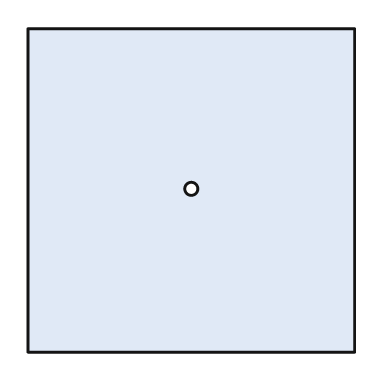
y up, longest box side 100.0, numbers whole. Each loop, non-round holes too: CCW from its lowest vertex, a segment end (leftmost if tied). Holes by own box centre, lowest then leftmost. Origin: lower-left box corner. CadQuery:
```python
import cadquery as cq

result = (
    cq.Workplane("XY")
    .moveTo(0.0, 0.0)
    .lineTo(100.0, 0.0)
    .lineTo(100.0, 99.0)
    .lineTo(0.0, 99.0)
    .close()
    .moveTo(50.0, 50.0)
    .circle(2.0)
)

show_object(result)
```